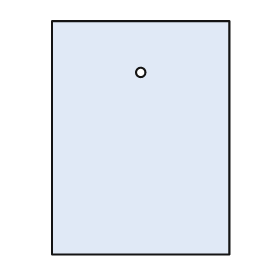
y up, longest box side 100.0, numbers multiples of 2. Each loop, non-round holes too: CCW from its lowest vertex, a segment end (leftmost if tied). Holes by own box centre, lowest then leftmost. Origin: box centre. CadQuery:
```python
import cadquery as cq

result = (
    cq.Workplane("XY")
    .moveTo(-38.0, -50.0)
    .lineTo(38.0, -50.0)
    .lineTo(38.0, 50.0)
    .lineTo(-38.0, 50.0)
    .close()
    .moveTo(0.0, 28.0)
    .circle(2.0)
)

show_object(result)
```